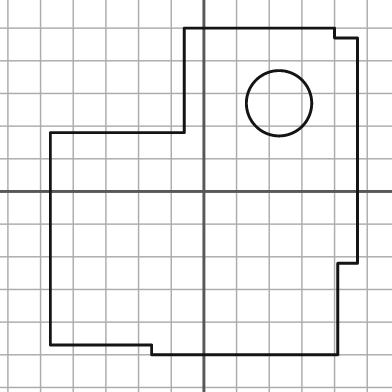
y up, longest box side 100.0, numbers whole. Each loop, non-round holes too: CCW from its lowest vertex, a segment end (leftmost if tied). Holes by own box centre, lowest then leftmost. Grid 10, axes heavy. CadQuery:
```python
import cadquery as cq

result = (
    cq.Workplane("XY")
    .moveTo(-16.0, -50.0)
    .lineTo(41.0, -50.0)
    .lineTo(41.0, -22.0)
    .lineTo(47.0, -22.0)
    .lineTo(47.0, 47.0)
    .lineTo(40.0, 47.0)
    .lineTo(40.0, 50.0)
    .lineTo(-6.0, 50.0)
    .lineTo(-6.0, 18.0)
    .lineTo(-47.0, 18.0)
    .lineTo(-47.0, -47.0)
    .lineTo(-16.0, -47.0)
    .close()
    .moveTo(23.0, 27.0)
    .circle(10.0)
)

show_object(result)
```